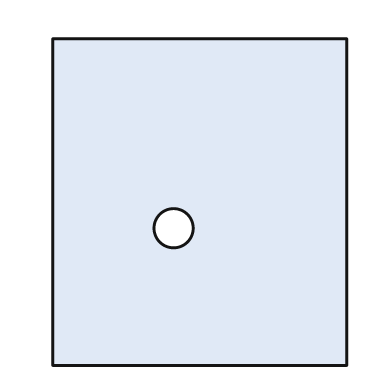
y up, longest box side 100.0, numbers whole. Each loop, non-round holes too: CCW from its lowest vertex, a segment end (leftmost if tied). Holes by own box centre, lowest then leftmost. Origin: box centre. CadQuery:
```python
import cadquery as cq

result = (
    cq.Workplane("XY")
    .moveTo(-45.0, -50.0)
    .lineTo(45.0, -50.0)
    .lineTo(45.0, 50.0)
    .lineTo(-45.0, 50.0)
    .close()
    .moveTo(-8.0, -8.0)
    .circle(6.0)
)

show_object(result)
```